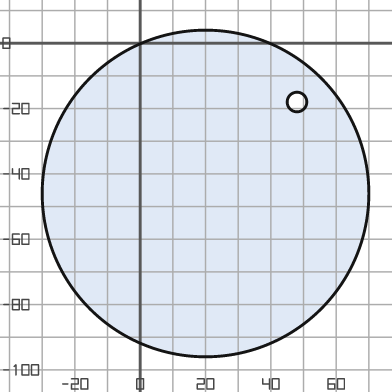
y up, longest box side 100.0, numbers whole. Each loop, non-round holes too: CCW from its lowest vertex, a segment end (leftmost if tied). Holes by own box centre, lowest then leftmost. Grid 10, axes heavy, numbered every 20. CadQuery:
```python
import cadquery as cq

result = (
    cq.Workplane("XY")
    .moveTo(20.0, -46.0)
    .circle(50.0)
    .moveTo(48.0, -18.0)
    .circle(3.0)
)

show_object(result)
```